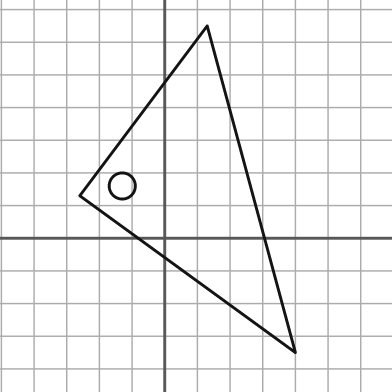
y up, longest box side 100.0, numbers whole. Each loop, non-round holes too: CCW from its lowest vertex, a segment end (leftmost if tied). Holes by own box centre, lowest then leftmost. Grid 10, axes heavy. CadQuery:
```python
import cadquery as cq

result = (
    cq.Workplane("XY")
    .moveTo(40.0, -35.0)
    .lineTo(13.0, 65.0)
    .lineTo(-26.0, 13.0)
    .close()
    .moveTo(-13.0, 16.0)
    .circle(4.0)
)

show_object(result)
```